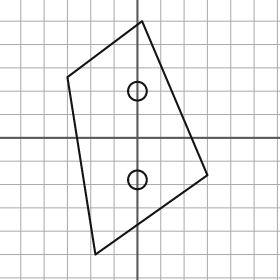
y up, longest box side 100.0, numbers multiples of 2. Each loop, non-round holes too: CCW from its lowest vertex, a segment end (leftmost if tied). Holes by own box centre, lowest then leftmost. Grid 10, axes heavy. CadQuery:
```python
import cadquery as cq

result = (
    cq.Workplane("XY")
    .moveTo(-18.0, -50.0)
    .lineTo(30.0, -16.0)
    .lineTo(2.0, 50.0)
    .lineTo(-30.0, 26.0)
    .close()
    .moveTo(0.0, -18.0)
    .circle(4.0)
    .moveTo(0.0, 20.0)
    .circle(4.0)
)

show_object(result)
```